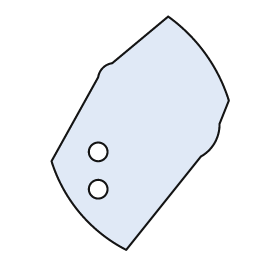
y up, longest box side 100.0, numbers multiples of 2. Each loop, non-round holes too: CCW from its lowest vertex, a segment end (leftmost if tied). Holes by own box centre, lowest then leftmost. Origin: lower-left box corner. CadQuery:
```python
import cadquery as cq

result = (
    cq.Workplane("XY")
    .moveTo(32.0, 0.0)
    .lineTo(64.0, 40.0)
    .threePointArc((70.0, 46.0), (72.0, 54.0))
    .lineTo(76.0, 64.0)
    .threePointArc((66.0, 84.0), (50.0, 100.0))
    .lineTo(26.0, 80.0)
    .threePointArc((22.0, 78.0), (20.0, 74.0))
    .lineTo(0.0, 38.0)
    .threePointArc((12.0, 16.0), (32.0, 0.0))
    .close()
    .moveTo(20.0, 26.0)
    .circle(4.0)
    .moveTo(20.0, 42.0)
    .circle(4.0)
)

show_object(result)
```